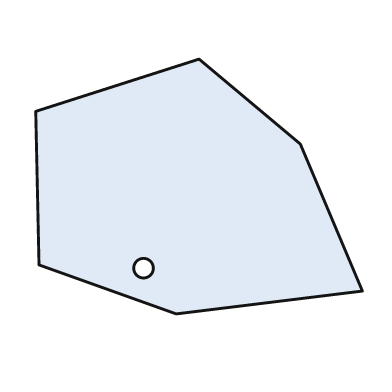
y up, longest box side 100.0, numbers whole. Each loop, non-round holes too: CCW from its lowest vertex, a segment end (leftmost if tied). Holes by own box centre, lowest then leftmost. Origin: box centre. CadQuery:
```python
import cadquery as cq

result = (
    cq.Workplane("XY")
    .moveTo(-7.0, -39.0)
    .lineTo(50.0, -32.0)
    .lineTo(31.0, 13.0)
    .lineTo(0.0, 39.0)
    .lineTo(-50.0, 23.0)
    .lineTo(-49.0, -24.0)
    .close()
    .moveTo(-17.0, -25.0)
    .circle(3.0)
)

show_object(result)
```